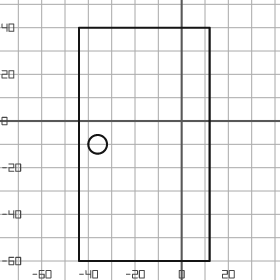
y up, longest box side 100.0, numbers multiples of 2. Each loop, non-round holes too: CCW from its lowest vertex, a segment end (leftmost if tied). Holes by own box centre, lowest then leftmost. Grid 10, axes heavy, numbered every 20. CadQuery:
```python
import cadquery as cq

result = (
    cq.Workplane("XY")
    .moveTo(-44.0, -60.0)
    .lineTo(12.0, -60.0)
    .lineTo(12.0, 40.0)
    .lineTo(-44.0, 40.0)
    .close()
    .moveTo(-36.0, -10.0)
    .circle(4.0)
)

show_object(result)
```